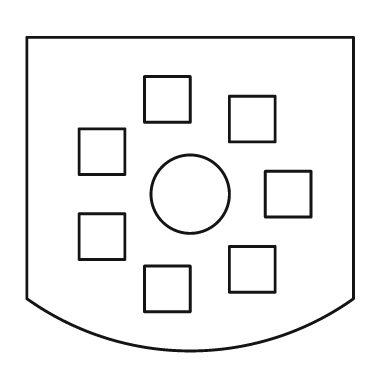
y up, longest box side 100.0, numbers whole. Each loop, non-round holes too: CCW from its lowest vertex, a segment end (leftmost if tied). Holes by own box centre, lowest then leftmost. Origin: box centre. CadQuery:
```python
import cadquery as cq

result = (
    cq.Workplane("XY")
    .moveTo(-50.0, -32.0)
    .threePointArc((0.0, -48.0), (50.0, -32.0))
    .lineTo(50.0, 48.0)
    .lineTo(-50.0, 48.0)
    .close()
    .moveTo(-14.0, -36.0)
    .lineTo(0.0, -36.0)
    .lineTo(0.0, -22.0)
    .lineTo(-14.0, -22.0)
    .close()
    .moveTo(12.0, -30.0)
    .lineTo(26.0, -30.0)
    .lineTo(26.0, -16.0)
    .lineTo(12.0, -16.0)
    .close()
    .moveTo(-34.0, -20.0)
    .lineTo(-20.0, -20.0)
    .lineTo(-20.0, -6.0)
    .lineTo(-34.0, -6.0)
    .close()
    .moveTo(0.0, 0.0)
    .circle(12.0)
    .moveTo(23.0, -7.0)
    .lineTo(37.0, -7.0)
    .lineTo(37.0, 7.0)
    .lineTo(23.0, 7.0)
    .close()
    .moveTo(-34.0, 6.0)
    .lineTo(-20.0, 6.0)
    .lineTo(-20.0, 20.0)
    .lineTo(-34.0, 20.0)
    .close()
    .moveTo(12.0, 16.0)
    .lineTo(26.0, 16.0)
    .lineTo(26.0, 30.0)
    .lineTo(12.0, 30.0)
    .close()
    .moveTo(-14.0, 22.0)
    .lineTo(0.0, 22.0)
    .lineTo(0.0, 36.0)
    .lineTo(-14.0, 36.0)
    .close()
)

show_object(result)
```